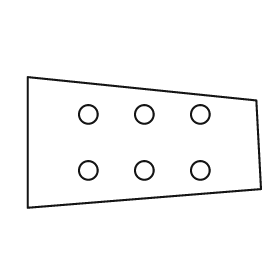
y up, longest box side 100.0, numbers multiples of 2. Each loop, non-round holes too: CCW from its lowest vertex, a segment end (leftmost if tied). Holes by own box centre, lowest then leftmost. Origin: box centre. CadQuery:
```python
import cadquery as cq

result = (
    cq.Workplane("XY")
    .moveTo(-50.0, -28.0)
    .lineTo(50.0, -20.0)
    .lineTo(48.0, 18.0)
    .lineTo(-50.0, 28.0)
    .close()
    .moveTo(-24.0, -12.0)
    .circle(4.0)
    .moveTo(0.0, -12.0)
    .circle(4.0)
    .moveTo(24.0, -12.0)
    .circle(4.0)
    .moveTo(-24.0, 12.0)
    .circle(4.0)
    .moveTo(0.0, 12.0)
    .circle(4.0)
    .moveTo(24.0, 12.0)
    .circle(4.0)
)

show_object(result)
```